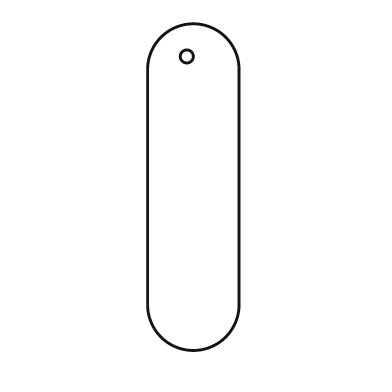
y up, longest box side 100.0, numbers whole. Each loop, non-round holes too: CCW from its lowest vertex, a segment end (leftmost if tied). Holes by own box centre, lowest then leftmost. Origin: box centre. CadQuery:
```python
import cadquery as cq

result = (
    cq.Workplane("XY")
    .moveTo(-14.0, -36.0)
    .threePointArc((0.0, -50.0), (14.0, -36.0))
    .lineTo(14.0, 36.0)
    .threePointArc((0.0, 50.0), (-14.0, 36.0))
    .close()
    .moveTo(-2.0, 40.0)
    .circle(2.0)
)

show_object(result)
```